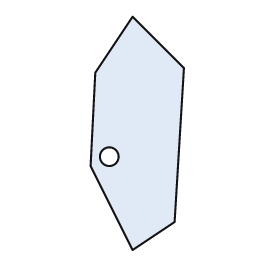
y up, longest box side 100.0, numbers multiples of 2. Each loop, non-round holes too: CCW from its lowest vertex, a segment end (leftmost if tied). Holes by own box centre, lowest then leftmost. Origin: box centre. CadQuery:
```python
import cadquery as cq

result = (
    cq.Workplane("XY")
    .moveTo(-2.0, -50.0)
    .lineTo(16.0, -38.0)
    .lineTo(20.0, 28.0)
    .lineTo(-2.0, 50.0)
    .lineTo(-18.0, 26.0)
    .lineTo(-20.0, -14.0)
    .close()
    .moveTo(-12.0, -10.0)
    .circle(4.0)
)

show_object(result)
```